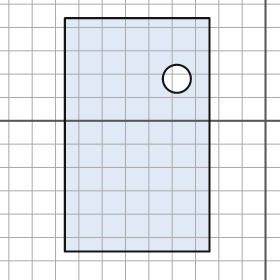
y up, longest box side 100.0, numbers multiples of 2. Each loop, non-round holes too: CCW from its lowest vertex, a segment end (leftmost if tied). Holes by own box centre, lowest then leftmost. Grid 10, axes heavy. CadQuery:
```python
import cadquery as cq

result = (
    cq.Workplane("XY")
    .moveTo(-86.0, -56.0)
    .lineTo(-24.0, -56.0)
    .lineTo(-24.0, 44.0)
    .lineTo(-86.0, 44.0)
    .close()
    .moveTo(-38.0, 18.0)
    .circle(6.0)
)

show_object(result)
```